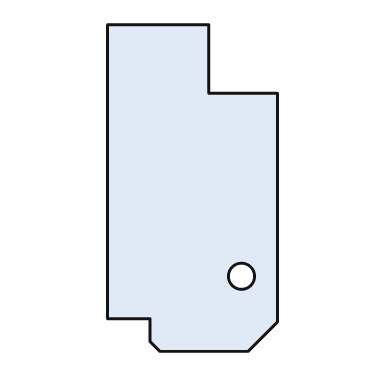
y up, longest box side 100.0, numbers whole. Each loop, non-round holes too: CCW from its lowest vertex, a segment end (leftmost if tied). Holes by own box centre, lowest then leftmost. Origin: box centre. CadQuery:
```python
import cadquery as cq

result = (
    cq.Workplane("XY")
    .moveTo(-10.0, -50.0)
    .lineTo(17.0, -50.0)
    .lineTo(26.0, -41.0)
    .lineTo(26.0, 29.0)
    .lineTo(5.0, 29.0)
    .lineTo(5.0, 50.0)
    .lineTo(-26.0, 50.0)
    .lineTo(-26.0, -40.0)
    .lineTo(-13.0, -40.0)
    .lineTo(-13.0, -47.0)
    .close()
    .moveTo(15.0, -27.0)
    .circle(4.0)
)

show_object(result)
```